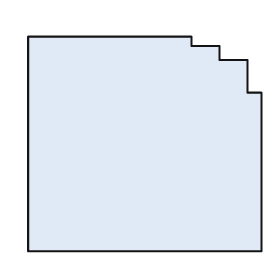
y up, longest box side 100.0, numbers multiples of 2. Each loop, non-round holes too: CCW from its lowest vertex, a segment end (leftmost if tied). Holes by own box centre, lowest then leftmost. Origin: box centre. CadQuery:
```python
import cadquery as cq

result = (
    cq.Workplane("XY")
    .moveTo(-50.0, -46.0)
    .lineTo(50.0, -46.0)
    .lineTo(50.0, 22.0)
    .lineTo(44.0, 22.0)
    .lineTo(44.0, 36.0)
    .lineTo(32.0, 36.0)
    .lineTo(32.0, 42.0)
    .lineTo(20.0, 42.0)
    .lineTo(20.0, 46.0)
    .lineTo(-50.0, 46.0)
    .close()
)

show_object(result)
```